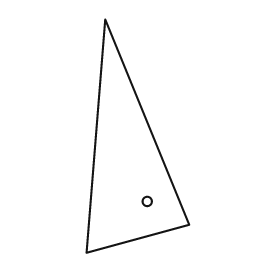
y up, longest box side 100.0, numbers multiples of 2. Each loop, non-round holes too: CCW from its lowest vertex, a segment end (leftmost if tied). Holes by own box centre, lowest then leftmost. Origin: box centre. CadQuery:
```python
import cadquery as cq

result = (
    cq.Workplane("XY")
    .moveTo(-22.0, -50.0)
    .lineTo(22.0, -38.0)
    .lineTo(-14.0, 50.0)
    .close()
    .moveTo(4.0, -28.0)
    .circle(2.0)
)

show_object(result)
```